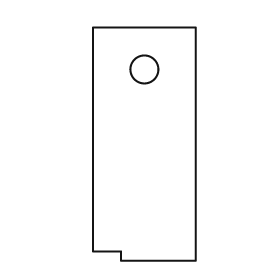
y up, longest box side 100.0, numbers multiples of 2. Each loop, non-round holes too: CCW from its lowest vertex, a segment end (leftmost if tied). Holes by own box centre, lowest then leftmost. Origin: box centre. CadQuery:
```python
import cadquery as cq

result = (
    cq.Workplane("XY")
    .moveTo(-10.0, -50.0)
    .lineTo(22.0, -50.0)
    .lineTo(22.0, 50.0)
    .lineTo(-22.0, 50.0)
    .lineTo(-22.0, -46.0)
    .lineTo(-10.0, -46.0)
    .close()
    .moveTo(0.0, 32.0)
    .circle(6.0)
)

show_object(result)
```